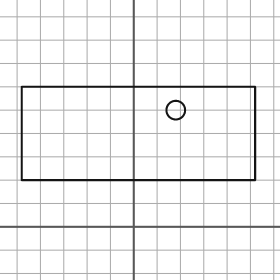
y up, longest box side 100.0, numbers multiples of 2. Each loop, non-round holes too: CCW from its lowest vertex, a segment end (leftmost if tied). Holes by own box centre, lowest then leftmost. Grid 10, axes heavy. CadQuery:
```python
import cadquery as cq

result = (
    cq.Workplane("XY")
    .moveTo(-48.0, 20.0)
    .lineTo(52.0, 20.0)
    .lineTo(52.0, 60.0)
    .lineTo(-48.0, 60.0)
    .close()
    .moveTo(18.0, 50.0)
    .circle(4.0)
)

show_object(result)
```